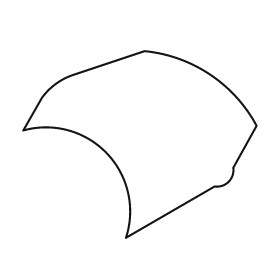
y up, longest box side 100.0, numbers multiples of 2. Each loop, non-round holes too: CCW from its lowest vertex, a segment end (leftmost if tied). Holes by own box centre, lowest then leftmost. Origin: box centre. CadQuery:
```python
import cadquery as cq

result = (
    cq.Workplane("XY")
    .moveTo(-6.0, -40.0)
    .lineTo(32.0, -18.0)
    .threePointArc((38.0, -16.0), (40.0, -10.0))
    .lineTo(50.0, 8.0)
    .threePointArc((30.0, 30.0), (2.0, 40.0))
    .lineTo(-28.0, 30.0)
    .threePointArc((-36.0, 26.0), (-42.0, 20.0))
    .lineTo(-50.0, 6.0)
    .threePointArc((-14.0, -4.0), (-6.0, -40.0))
    .close()
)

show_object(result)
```